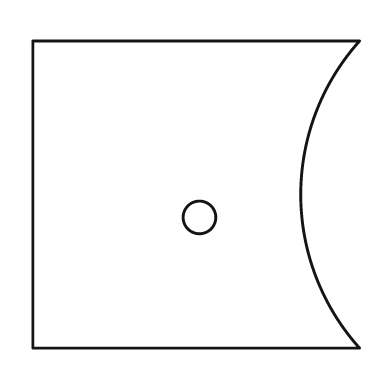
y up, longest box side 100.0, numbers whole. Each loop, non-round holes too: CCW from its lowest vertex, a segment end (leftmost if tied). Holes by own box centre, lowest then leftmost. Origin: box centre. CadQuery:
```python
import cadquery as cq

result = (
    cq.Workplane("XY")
    .moveTo(-50.0, -47.0)
    .lineTo(50.0, -47.0)
    .threePointArc((32.0, 0.0), (50.0, 47.0))
    .lineTo(-50.0, 47.0)
    .close()
    .moveTo(1.0, -7.0)
    .circle(5.0)
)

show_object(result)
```